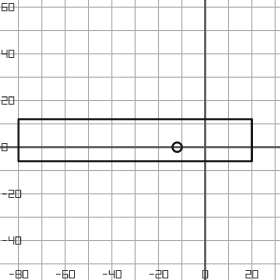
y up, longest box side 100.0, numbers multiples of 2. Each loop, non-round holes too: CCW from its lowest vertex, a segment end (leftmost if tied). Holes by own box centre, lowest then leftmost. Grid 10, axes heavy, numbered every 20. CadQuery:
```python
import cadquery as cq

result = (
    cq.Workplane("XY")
    .moveTo(-80.0, -6.0)
    .lineTo(20.0, -6.0)
    .lineTo(20.0, 12.0)
    .lineTo(-80.0, 12.0)
    .close()
    .moveTo(-12.0, 0.0)
    .circle(2.0)
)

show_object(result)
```